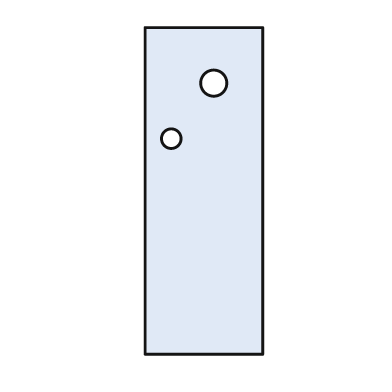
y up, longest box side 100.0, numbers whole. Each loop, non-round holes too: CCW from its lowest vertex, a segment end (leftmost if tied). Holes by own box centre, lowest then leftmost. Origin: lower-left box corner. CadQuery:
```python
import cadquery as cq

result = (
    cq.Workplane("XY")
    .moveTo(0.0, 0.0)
    .lineTo(36.0, 0.0)
    .lineTo(36.0, 100.0)
    .lineTo(0.0, 100.0)
    .close()
    .moveTo(8.0, 66.0)
    .circle(3.0)
    .moveTo(21.0, 83.0)
    .circle(4.0)
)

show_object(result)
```